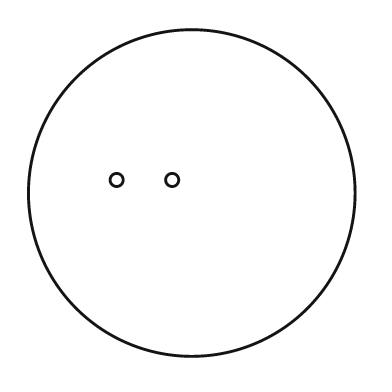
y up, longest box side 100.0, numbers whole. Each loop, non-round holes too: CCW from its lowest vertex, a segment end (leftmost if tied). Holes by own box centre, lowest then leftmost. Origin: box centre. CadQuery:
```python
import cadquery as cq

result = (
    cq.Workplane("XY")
    .moveTo(0.0, 0.0)
    .circle(50.0)
    .moveTo(-23.0, 4.0)
    .circle(2.0)
    .moveTo(-6.0, 4.0)
    .circle(2.0)
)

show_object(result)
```